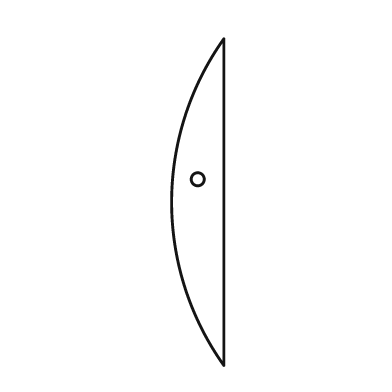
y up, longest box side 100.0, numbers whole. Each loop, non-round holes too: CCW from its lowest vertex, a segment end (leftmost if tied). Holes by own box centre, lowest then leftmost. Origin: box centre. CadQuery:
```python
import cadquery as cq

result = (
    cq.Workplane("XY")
    .moveTo(8.0, -50.0)
    .lineTo(8.0, 50.0)
    .threePointArc((-8.0, 0.0), (8.0, -50.0))
    .close()
    .moveTo(0.0, 7.0)
    .circle(2.0)
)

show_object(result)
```